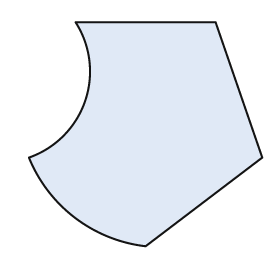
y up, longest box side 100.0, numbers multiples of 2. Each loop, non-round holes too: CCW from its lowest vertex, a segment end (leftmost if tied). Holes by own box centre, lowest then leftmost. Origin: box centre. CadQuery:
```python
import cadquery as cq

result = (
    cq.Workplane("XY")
    .moveTo(0.0, -48.0)
    .lineTo(50.0, -10.0)
    .lineTo(30.0, 48.0)
    .lineTo(-30.0, 48.0)
    .threePointArc((-26.0, 14.0), (-50.0, -10.0))
    .threePointArc((-30.0, -36.0), (0.0, -48.0))
    .close()
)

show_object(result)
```